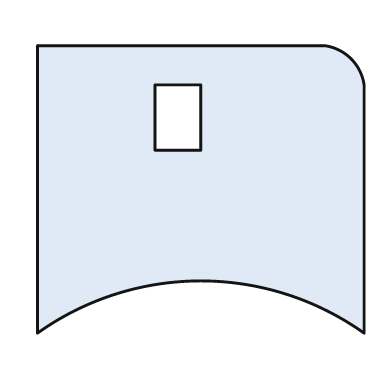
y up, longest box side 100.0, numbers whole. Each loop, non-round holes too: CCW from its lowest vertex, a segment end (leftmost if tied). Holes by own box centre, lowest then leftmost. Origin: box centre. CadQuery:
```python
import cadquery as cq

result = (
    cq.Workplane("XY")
    .moveTo(-50.0, -44.0)
    .threePointArc((0.0, -28.0), (50.0, -44.0))
    .lineTo(50.0, 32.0)
    .threePointArc((46.0, 40.0), (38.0, 44.0))
    .lineTo(-50.0, 44.0)
    .close()
    .moveTo(-14.0, 12.0)
    .lineTo(0.0, 12.0)
    .lineTo(0.0, 32.0)
    .lineTo(-14.0, 32.0)
    .close()
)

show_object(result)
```